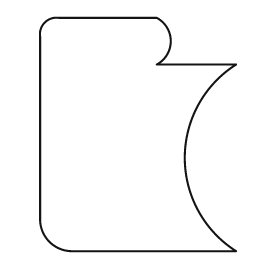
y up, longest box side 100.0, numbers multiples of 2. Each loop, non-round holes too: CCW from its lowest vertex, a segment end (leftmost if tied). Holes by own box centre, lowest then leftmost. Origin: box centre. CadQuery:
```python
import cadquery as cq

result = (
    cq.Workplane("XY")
    .moveTo(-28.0, -50.0)
    .lineTo(42.0, -50.0)
    .threePointArc((20.0, -10.0), (42.0, 30.0))
    .lineTo(8.0, 30.0)
    .threePointArc((14.0, 40.0), (8.0, 50.0))
    .lineTo(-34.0, 50.0)
    .threePointArc((-40.0, 48.0), (-42.0, 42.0))
    .lineTo(-42.0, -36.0)
    .threePointArc((-38.0, -46.0), (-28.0, -50.0))
    .close()
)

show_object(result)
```